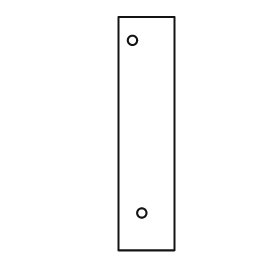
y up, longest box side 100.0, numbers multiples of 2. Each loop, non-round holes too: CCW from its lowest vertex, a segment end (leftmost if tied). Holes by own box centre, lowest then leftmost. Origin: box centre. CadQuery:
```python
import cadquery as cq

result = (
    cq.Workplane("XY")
    .moveTo(-12.0, -50.0)
    .lineTo(12.0, -50.0)
    .lineTo(12.0, 50.0)
    .lineTo(-12.0, 50.0)
    .close()
    .moveTo(-2.0, -34.0)
    .circle(2.0)
    .moveTo(-6.0, 40.0)
    .circle(2.0)
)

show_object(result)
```